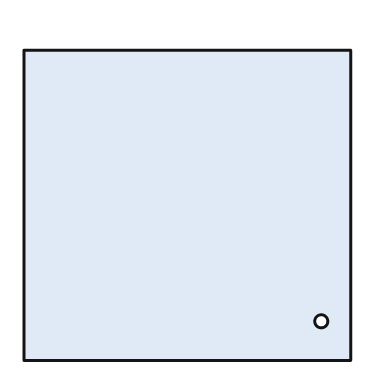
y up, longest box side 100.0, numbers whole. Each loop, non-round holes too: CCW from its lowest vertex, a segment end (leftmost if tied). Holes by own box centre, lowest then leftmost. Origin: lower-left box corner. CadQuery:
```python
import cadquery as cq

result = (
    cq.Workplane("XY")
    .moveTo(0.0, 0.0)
    .lineTo(100.0, 0.0)
    .lineTo(100.0, 95.0)
    .lineTo(0.0, 95.0)
    .close()
    .moveTo(91.0, 12.0)
    .circle(2.0)
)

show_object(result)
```